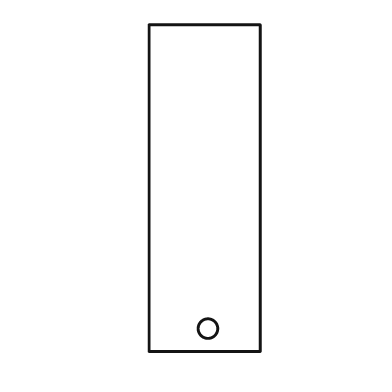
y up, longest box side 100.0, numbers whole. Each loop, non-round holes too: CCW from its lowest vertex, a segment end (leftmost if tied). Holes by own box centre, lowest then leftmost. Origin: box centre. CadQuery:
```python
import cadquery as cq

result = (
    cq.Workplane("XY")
    .moveTo(-17.0, -50.0)
    .lineTo(17.0, -50.0)
    .lineTo(17.0, 50.0)
    .lineTo(-17.0, 50.0)
    .close()
    .moveTo(1.0, -43.0)
    .circle(3.0)
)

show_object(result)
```